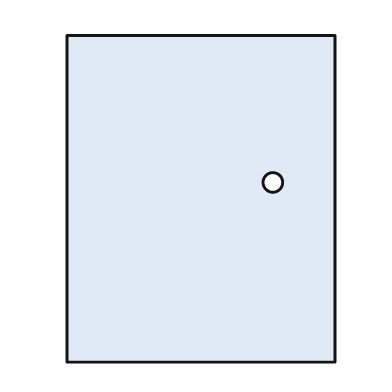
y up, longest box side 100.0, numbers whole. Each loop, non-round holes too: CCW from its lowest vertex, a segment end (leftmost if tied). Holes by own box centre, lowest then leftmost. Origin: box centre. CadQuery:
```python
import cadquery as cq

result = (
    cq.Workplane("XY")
    .moveTo(-41.0, -50.0)
    .lineTo(41.0, -50.0)
    .lineTo(41.0, 50.0)
    .lineTo(-41.0, 50.0)
    .close()
    .moveTo(22.0, 5.0)
    .circle(3.0)
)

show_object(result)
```